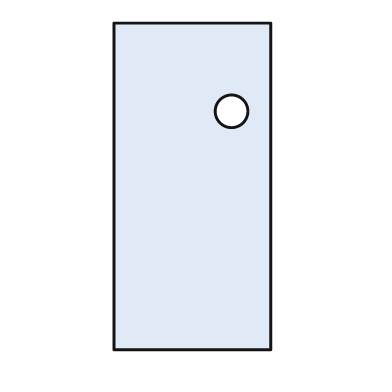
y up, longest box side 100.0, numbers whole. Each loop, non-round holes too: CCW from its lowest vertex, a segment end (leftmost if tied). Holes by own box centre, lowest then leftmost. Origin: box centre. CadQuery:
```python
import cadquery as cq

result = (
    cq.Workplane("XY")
    .moveTo(-24.0, -50.0)
    .lineTo(24.0, -50.0)
    .lineTo(24.0, 50.0)
    .lineTo(-24.0, 50.0)
    .close()
    .moveTo(12.0, 23.0)
    .circle(5.0)
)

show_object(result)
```